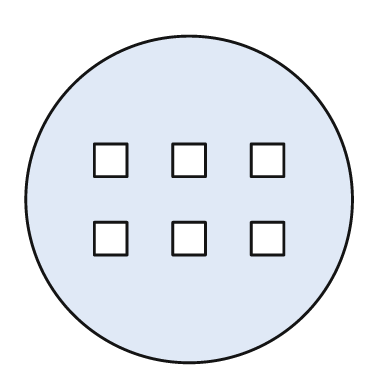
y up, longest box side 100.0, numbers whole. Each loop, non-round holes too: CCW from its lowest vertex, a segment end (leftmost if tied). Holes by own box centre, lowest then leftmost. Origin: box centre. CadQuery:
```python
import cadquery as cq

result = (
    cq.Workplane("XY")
    .moveTo(0.0, 0.0)
    .circle(50.0)
    .moveTo(-29.0, -17.0)
    .lineTo(-19.0, -17.0)
    .lineTo(-19.0, -7.0)
    .lineTo(-29.0, -7.0)
    .close()
    .moveTo(-5.0, -17.0)
    .lineTo(5.0, -17.0)
    .lineTo(5.0, -7.0)
    .lineTo(-5.0, -7.0)
    .close()
    .moveTo(19.0, -17.0)
    .lineTo(29.0, -17.0)
    .lineTo(29.0, -7.0)
    .lineTo(19.0, -7.0)
    .close()
    .moveTo(-29.0, 7.0)
    .lineTo(-19.0, 7.0)
    .lineTo(-19.0, 17.0)
    .lineTo(-29.0, 17.0)
    .close()
    .moveTo(-5.0, 7.0)
    .lineTo(5.0, 7.0)
    .lineTo(5.0, 17.0)
    .lineTo(-5.0, 17.0)
    .close()
    .moveTo(19.0, 7.0)
    .lineTo(29.0, 7.0)
    .lineTo(29.0, 17.0)
    .lineTo(19.0, 17.0)
    .close()
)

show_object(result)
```